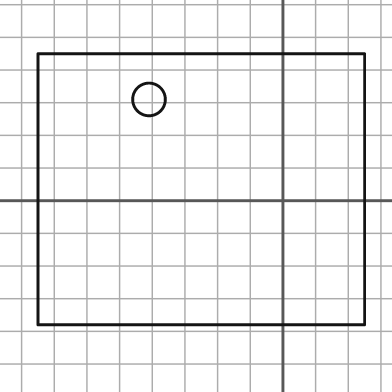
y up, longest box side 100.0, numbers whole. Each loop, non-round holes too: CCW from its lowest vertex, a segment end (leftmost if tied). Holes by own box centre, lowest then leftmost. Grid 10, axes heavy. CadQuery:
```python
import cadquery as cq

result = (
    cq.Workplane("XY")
    .moveTo(-75.0, -38.0)
    .lineTo(25.0, -38.0)
    .lineTo(25.0, 45.0)
    .lineTo(-75.0, 45.0)
    .close()
    .moveTo(-41.0, 31.0)
    .circle(5.0)
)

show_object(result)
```